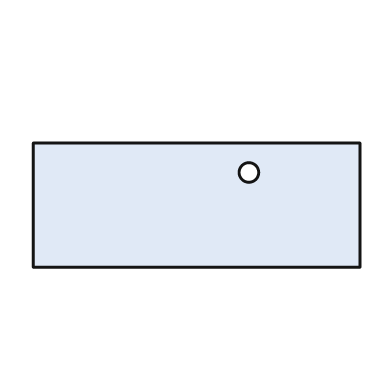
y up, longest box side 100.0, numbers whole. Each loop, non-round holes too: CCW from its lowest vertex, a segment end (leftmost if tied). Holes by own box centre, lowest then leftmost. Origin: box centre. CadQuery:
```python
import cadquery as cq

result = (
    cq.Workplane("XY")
    .moveTo(-50.0, -19.0)
    .lineTo(50.0, -19.0)
    .lineTo(50.0, 19.0)
    .lineTo(-50.0, 19.0)
    .close()
    .moveTo(16.0, 10.0)
    .circle(3.0)
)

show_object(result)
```